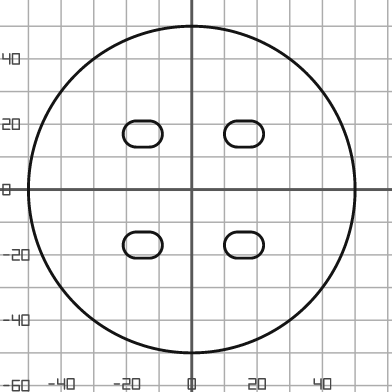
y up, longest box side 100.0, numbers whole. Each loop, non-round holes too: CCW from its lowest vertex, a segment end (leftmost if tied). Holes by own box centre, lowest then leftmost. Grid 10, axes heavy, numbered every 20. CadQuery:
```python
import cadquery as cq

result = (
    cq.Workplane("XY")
    .moveTo(0.0, 0.0)
    .circle(50.0)
    .moveTo(-17.0, -21.0)
    .lineTo(-13.0, -21.0)
    .threePointArc((-9.0, -17.0), (-13.0, -13.0))
    .lineTo(-17.0, -13.0)
    .threePointArc((-21.0, -17.0), (-17.0, -21.0))
    .close()
    .moveTo(14.0, -21.0)
    .lineTo(18.0, -21.0)
    .threePointArc((22.0, -17.0), (18.0, -13.0))
    .lineTo(14.0, -13.0)
    .threePointArc((10.0, -17.0), (14.0, -21.0))
    .close()
    .moveTo(-17.0, 13.0)
    .lineTo(-13.0, 13.0)
    .threePointArc((-9.0, 17.0), (-13.0, 21.0))
    .lineTo(-17.0, 21.0)
    .threePointArc((-21.0, 17.0), (-17.0, 13.0))
    .close()
    .moveTo(14.0, 13.0)
    .lineTo(18.0, 13.0)
    .threePointArc((22.0, 17.0), (18.0, 21.0))
    .lineTo(14.0, 21.0)
    .threePointArc((10.0, 17.0), (14.0, 13.0))
    .close()
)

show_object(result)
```